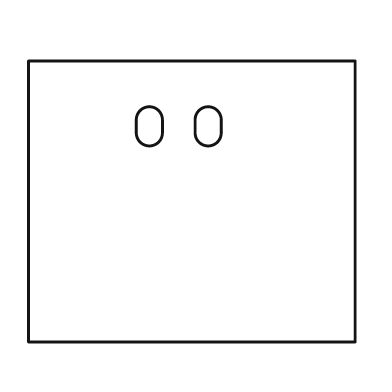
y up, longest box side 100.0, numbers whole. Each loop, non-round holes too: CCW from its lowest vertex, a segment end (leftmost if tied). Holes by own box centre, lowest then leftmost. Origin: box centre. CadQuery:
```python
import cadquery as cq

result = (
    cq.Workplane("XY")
    .moveTo(-50.0, -43.0)
    .lineTo(50.0, -43.0)
    .lineTo(50.0, 43.0)
    .lineTo(-50.0, 43.0)
    .close()
    .moveTo(-17.0, 21.0)
    .threePointArc((-13.0, 17.0), (-9.0, 21.0))
    .lineTo(-9.0, 25.0)
    .threePointArc((-13.0, 29.0), (-17.0, 25.0))
    .close()
    .moveTo(1.0, 21.0)
    .threePointArc((5.0, 17.0), (9.0, 21.0))
    .lineTo(9.0, 25.0)
    .threePointArc((5.0, 29.0), (1.0, 25.0))
    .close()
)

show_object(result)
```